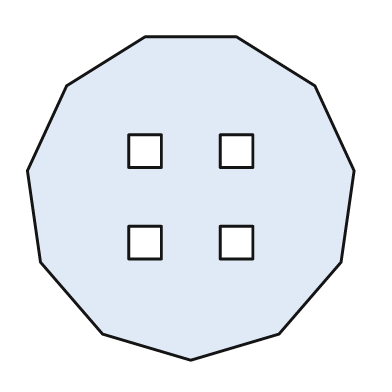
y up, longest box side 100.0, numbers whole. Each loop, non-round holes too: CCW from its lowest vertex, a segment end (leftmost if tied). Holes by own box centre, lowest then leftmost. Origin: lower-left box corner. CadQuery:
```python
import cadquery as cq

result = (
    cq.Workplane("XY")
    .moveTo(50.0, 0.0)
    .lineTo(77.0, 8.0)
    .lineTo(96.0, 30.0)
    .lineTo(100.0, 58.0)
    .lineTo(88.0, 84.0)
    .lineTo(64.0, 99.0)
    .lineTo(36.0, 99.0)
    .lineTo(12.0, 84.0)
    .lineTo(0.0, 58.0)
    .lineTo(4.0, 30.0)
    .lineTo(23.0, 8.0)
    .close()
    .moveTo(31.0, 31.0)
    .lineTo(41.0, 31.0)
    .lineTo(41.0, 41.0)
    .lineTo(31.0, 41.0)
    .close()
    .moveTo(59.0, 31.0)
    .lineTo(69.0, 31.0)
    .lineTo(69.0, 41.0)
    .lineTo(59.0, 41.0)
    .close()
    .moveTo(31.0, 59.0)
    .lineTo(41.0, 59.0)
    .lineTo(41.0, 69.0)
    .lineTo(31.0, 69.0)
    .close()
    .moveTo(59.0, 59.0)
    .lineTo(69.0, 59.0)
    .lineTo(69.0, 69.0)
    .lineTo(59.0, 69.0)
    .close()
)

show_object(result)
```